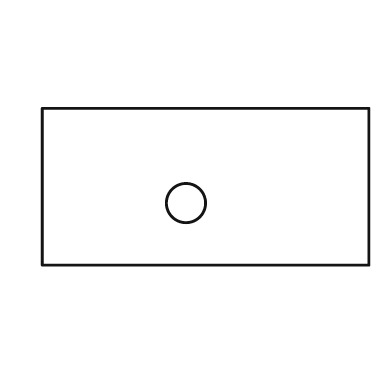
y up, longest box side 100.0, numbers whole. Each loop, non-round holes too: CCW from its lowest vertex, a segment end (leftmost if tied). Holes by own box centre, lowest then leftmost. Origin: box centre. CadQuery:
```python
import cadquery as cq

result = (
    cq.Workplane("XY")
    .moveTo(-50.0, -24.0)
    .lineTo(50.0, -24.0)
    .lineTo(50.0, 24.0)
    .lineTo(-50.0, 24.0)
    .close()
    .moveTo(-6.0, -5.0)
    .circle(6.0)
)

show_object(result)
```